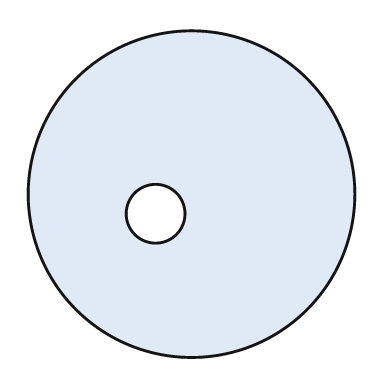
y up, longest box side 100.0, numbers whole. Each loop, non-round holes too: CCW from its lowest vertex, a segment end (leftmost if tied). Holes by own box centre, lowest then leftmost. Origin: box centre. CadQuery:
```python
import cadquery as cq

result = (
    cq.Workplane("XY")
    .moveTo(0.0, 0.0)
    .circle(50.0)
    .moveTo(-11.0, -6.0)
    .circle(9.0)
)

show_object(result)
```